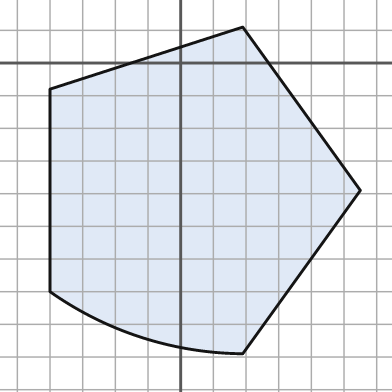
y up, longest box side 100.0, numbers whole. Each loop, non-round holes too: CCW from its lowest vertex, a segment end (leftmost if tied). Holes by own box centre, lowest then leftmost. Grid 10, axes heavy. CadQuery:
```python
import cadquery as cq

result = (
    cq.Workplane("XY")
    .moveTo(19.0, -89.0)
    .lineTo(55.0, -39.0)
    .lineTo(19.0, 11.0)
    .lineTo(-40.0, -8.0)
    .lineTo(-40.0, -70.0)
    .threePointArc((-12.0, -84.0), (19.0, -89.0))
    .close()
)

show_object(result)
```